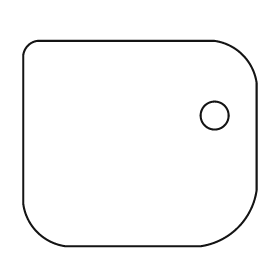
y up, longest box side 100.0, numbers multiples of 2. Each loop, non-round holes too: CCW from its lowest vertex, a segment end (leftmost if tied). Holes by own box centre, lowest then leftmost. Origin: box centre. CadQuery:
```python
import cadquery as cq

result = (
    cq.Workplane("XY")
    .moveTo(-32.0, -44.0)
    .lineTo(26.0, -44.0)
    .threePointArc((42.0, -36.0), (50.0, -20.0))
    .lineTo(50.0, 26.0)
    .threePointArc((44.0, 38.0), (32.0, 44.0))
    .lineTo(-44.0, 44.0)
    .threePointArc((-48.0, 42.0), (-50.0, 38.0))
    .lineTo(-50.0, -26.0)
    .threePointArc((-44.0, -38.0), (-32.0, -44.0))
    .close()
    .moveTo(32.0, 12.0)
    .circle(6.0)
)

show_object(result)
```